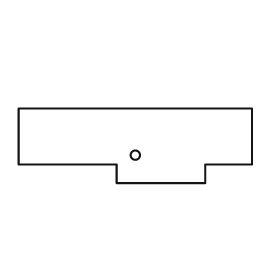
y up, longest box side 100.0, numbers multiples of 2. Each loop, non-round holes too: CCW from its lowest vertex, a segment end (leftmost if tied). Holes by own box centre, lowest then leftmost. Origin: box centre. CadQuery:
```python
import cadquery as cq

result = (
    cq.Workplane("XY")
    .moveTo(-8.0, -16.0)
    .lineTo(30.0, -16.0)
    .lineTo(30.0, -8.0)
    .lineTo(50.0, -8.0)
    .lineTo(50.0, 16.0)
    .lineTo(-50.0, 16.0)
    .lineTo(-50.0, -8.0)
    .lineTo(-8.0, -8.0)
    .close()
    .moveTo(0.0, -4.0)
    .circle(2.0)
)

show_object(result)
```